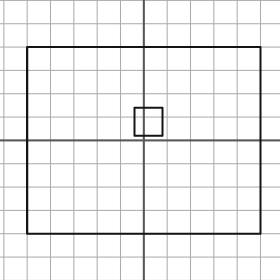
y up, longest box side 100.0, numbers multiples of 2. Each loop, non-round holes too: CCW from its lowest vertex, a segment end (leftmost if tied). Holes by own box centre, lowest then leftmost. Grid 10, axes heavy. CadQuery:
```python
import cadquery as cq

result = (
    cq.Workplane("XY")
    .moveTo(-50.0, -40.0)
    .lineTo(50.0, -40.0)
    .lineTo(50.0, 40.0)
    .lineTo(-50.0, 40.0)
    .close()
    .moveTo(-4.0, 2.0)
    .lineTo(8.0, 2.0)
    .lineTo(8.0, 14.0)
    .lineTo(-4.0, 14.0)
    .close()
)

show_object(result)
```